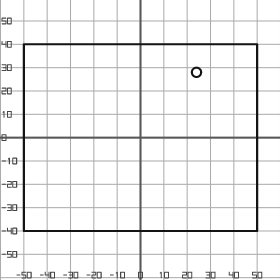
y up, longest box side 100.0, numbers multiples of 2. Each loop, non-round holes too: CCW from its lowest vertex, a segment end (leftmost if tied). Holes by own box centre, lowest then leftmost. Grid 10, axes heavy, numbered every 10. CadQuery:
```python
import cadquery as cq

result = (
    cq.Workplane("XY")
    .moveTo(-50.0, -40.0)
    .lineTo(50.0, -40.0)
    .lineTo(50.0, 40.0)
    .lineTo(-50.0, 40.0)
    .close()
    .moveTo(24.0, 28.0)
    .circle(2.0)
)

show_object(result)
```